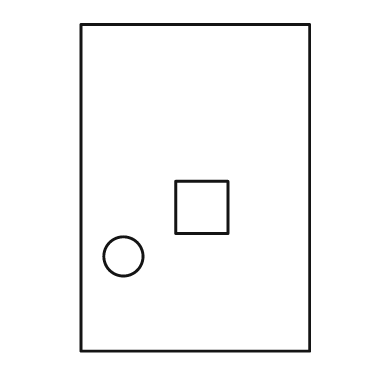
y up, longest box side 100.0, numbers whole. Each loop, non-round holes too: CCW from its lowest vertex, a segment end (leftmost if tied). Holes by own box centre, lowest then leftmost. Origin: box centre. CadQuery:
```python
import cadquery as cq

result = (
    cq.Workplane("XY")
    .moveTo(-35.0, -50.0)
    .lineTo(35.0, -50.0)
    .lineTo(35.0, 50.0)
    .lineTo(-35.0, 50.0)
    .close()
    .moveTo(-22.0, -21.0)
    .circle(6.0)
    .moveTo(-6.0, -14.0)
    .lineTo(10.0, -14.0)
    .lineTo(10.0, 2.0)
    .lineTo(-6.0, 2.0)
    .close()
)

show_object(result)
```